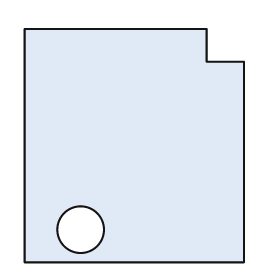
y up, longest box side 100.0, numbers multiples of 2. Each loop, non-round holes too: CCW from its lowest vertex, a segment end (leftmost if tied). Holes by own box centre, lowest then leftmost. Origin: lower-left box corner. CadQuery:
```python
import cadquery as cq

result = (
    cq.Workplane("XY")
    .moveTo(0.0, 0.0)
    .lineTo(94.0, 0.0)
    .lineTo(94.0, 86.0)
    .lineTo(78.0, 86.0)
    .lineTo(78.0, 100.0)
    .lineTo(0.0, 100.0)
    .close()
    .moveTo(24.0, 14.0)
    .circle(10.0)
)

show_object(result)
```